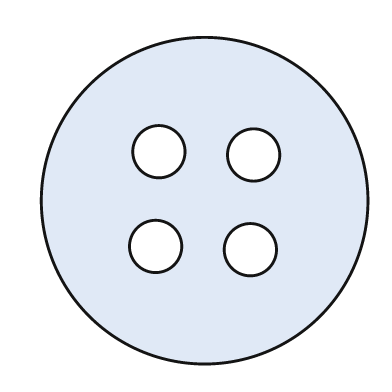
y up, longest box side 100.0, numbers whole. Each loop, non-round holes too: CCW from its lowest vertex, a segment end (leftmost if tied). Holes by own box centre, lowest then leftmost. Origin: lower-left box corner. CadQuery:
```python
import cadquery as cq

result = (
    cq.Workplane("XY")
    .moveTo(50.0, 50.0)
    .circle(50.0)
    .moveTo(64.0, 35.0)
    .circle(8.0)
    .moveTo(35.0, 36.0)
    .circle(8.0)
    .moveTo(65.0, 64.0)
    .circle(8.0)
    .moveTo(36.0, 65.0)
    .circle(8.0)
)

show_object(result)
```